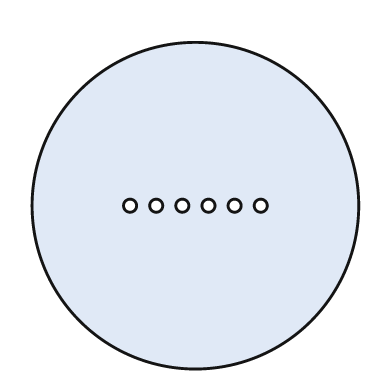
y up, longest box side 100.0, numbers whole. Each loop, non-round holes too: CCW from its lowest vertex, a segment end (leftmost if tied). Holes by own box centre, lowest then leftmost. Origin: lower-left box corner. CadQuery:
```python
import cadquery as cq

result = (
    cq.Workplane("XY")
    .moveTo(50.0, 50.0)
    .circle(50.0)
    .moveTo(30.0, 50.0)
    .circle(2.0)
    .moveTo(38.0, 50.0)
    .circle(2.0)
    .moveTo(46.0, 50.0)
    .circle(2.0)
    .moveTo(54.0, 50.0)
    .circle(2.0)
    .moveTo(62.0, 50.0)
    .circle(2.0)
    .moveTo(70.0, 50.0)
    .circle(2.0)
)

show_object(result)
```